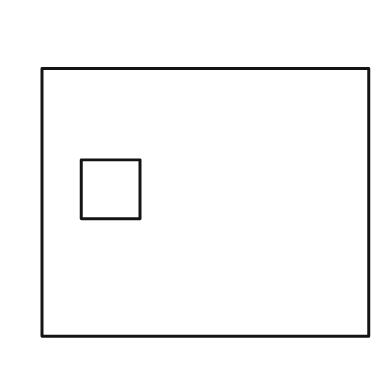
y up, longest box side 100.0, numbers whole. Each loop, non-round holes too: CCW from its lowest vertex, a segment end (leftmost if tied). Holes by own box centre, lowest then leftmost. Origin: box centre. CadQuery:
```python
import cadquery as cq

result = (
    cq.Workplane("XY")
    .moveTo(-50.0, -41.0)
    .lineTo(50.0, -41.0)
    .lineTo(50.0, 41.0)
    .lineTo(-50.0, 41.0)
    .close()
    .moveTo(-38.0, -5.0)
    .lineTo(-20.0, -5.0)
    .lineTo(-20.0, 13.0)
    .lineTo(-38.0, 13.0)
    .close()
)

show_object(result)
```